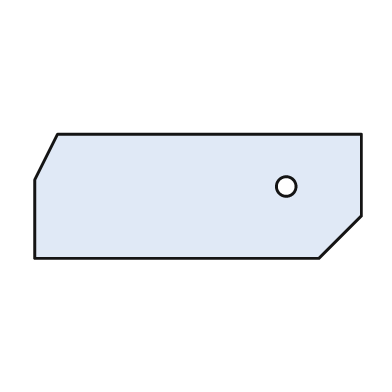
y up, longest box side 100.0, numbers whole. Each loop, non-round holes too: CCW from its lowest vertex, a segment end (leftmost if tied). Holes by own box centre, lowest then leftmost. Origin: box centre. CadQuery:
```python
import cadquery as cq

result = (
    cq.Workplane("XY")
    .moveTo(-50.0, -19.0)
    .lineTo(37.0, -19.0)
    .lineTo(50.0, -6.0)
    .lineTo(50.0, 19.0)
    .lineTo(-43.0, 19.0)
    .lineTo(-50.0, 5.0)
    .close()
    .moveTo(27.0, 3.0)
    .circle(3.0)
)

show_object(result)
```